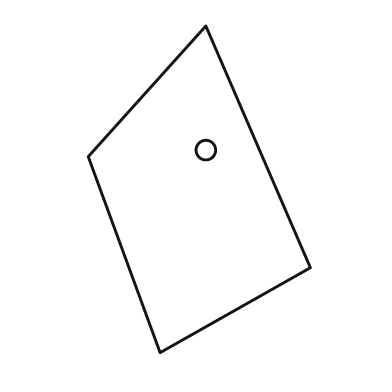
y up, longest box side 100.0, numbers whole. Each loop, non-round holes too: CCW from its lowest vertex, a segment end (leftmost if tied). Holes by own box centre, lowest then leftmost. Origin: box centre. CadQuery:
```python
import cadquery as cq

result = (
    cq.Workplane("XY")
    .moveTo(-12.0, -50.0)
    .lineTo(34.0, -24.0)
    .lineTo(2.0, 50.0)
    .lineTo(-34.0, 10.0)
    .close()
    .moveTo(2.0, 12.0)
    .circle(3.0)
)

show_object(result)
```